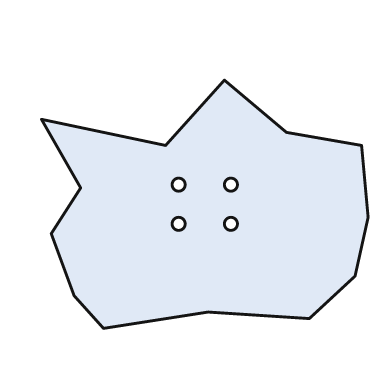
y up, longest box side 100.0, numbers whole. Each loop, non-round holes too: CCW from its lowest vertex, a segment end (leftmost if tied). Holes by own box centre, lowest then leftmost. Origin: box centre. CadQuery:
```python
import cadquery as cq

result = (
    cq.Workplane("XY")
    .moveTo(-31.0, -38.0)
    .lineTo(1.0, -33.0)
    .lineTo(32.0, -35.0)
    .lineTo(46.0, -22.0)
    .lineTo(50.0, -4.0)
    .lineTo(48.0, 18.0)
    .lineTo(25.0, 22.0)
    .lineTo(6.0, 38.0)
    .lineTo(-12.0, 18.0)
    .lineTo(-50.0, 26.0)
    .lineTo(-38.0, 5.0)
    .lineTo(-47.0, -9.0)
    .lineTo(-40.0, -28.0)
    .close()
    .moveTo(-8.0, -6.0)
    .circle(2.0)
    .moveTo(8.0, -6.0)
    .circle(2.0)
    .moveTo(-8.0, 6.0)
    .circle(2.0)
    .moveTo(8.0, 6.0)
    .circle(2.0)
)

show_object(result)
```